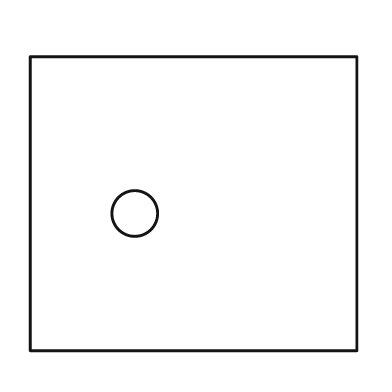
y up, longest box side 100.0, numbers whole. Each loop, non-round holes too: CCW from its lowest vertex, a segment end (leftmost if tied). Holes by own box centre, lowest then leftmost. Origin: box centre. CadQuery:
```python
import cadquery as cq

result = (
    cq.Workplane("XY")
    .moveTo(-50.0, -45.0)
    .lineTo(50.0, -45.0)
    .lineTo(50.0, 45.0)
    .lineTo(-50.0, 45.0)
    .close()
    .moveTo(-18.0, -3.0)
    .circle(7.0)
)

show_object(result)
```